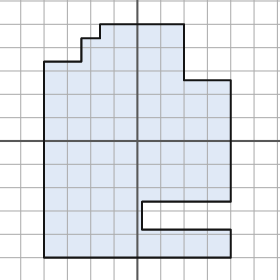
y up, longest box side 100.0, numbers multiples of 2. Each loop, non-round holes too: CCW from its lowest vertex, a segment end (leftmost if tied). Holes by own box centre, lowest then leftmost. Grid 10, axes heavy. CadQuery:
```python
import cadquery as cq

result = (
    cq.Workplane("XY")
    .moveTo(-40.0, -50.0)
    .lineTo(40.0, -50.0)
    .lineTo(40.0, -38.0)
    .lineTo(2.0, -38.0)
    .lineTo(2.0, -26.0)
    .lineTo(40.0, -26.0)
    .lineTo(40.0, 26.0)
    .lineTo(20.0, 26.0)
    .lineTo(20.0, 50.0)
    .lineTo(-16.0, 50.0)
    .lineTo(-16.0, 44.0)
    .lineTo(-24.0, 44.0)
    .lineTo(-24.0, 34.0)
    .lineTo(-40.0, 34.0)
    .close()
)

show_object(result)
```